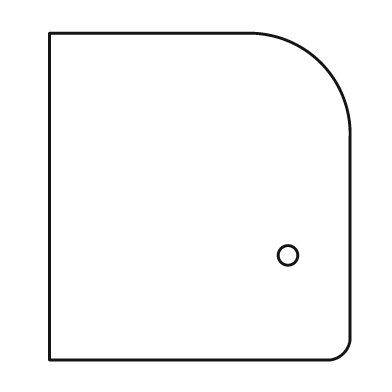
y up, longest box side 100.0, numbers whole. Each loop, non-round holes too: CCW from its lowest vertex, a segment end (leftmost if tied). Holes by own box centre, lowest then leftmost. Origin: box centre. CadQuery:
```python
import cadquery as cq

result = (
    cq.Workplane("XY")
    .moveTo(-46.0, -50.0)
    .lineTo(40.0, -50.0)
    .threePointArc((44.0, -48.0), (46.0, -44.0))
    .lineTo(46.0, 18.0)
    .threePointArc((37.0, 41.0), (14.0, 50.0))
    .lineTo(-46.0, 50.0)
    .close()
    .moveTo(27.0, -18.0)
    .circle(3.0)
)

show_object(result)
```